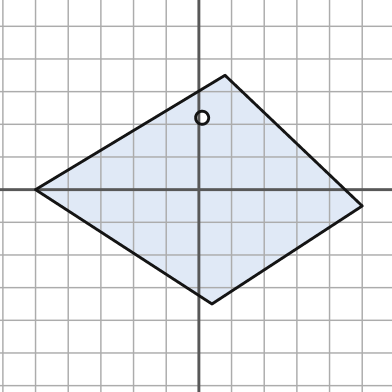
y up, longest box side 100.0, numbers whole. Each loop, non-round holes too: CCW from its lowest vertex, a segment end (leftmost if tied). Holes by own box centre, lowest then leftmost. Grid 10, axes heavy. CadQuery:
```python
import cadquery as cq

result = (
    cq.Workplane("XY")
    .moveTo(4.0, -35.0)
    .lineTo(50.0, -5.0)
    .lineTo(8.0, 35.0)
    .lineTo(-50.0, 0.0)
    .close()
    .moveTo(1.0, 22.0)
    .circle(2.0)
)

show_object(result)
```